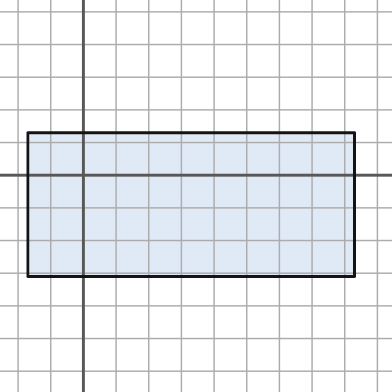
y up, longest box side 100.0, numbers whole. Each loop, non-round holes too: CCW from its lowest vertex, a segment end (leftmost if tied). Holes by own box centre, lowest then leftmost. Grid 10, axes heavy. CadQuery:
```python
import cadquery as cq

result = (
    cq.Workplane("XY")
    .moveTo(-17.0, -31.0)
    .lineTo(83.0, -31.0)
    .lineTo(83.0, 13.0)
    .lineTo(-17.0, 13.0)
    .close()
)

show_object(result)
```